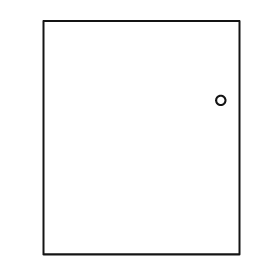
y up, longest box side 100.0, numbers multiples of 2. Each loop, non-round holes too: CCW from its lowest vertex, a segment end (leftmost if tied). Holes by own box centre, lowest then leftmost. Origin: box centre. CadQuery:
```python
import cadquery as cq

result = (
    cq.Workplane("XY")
    .moveTo(-42.0, -50.0)
    .lineTo(42.0, -50.0)
    .lineTo(42.0, 50.0)
    .lineTo(-42.0, 50.0)
    .close()
    .moveTo(34.0, 16.0)
    .circle(2.0)
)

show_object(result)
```